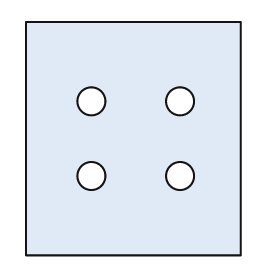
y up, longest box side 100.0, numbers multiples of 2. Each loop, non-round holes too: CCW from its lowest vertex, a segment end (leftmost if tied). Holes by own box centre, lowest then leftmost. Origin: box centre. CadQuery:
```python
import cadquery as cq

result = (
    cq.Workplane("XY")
    .moveTo(-46.0, -50.0)
    .lineTo(46.0, -50.0)
    .lineTo(46.0, 50.0)
    .lineTo(-46.0, 50.0)
    .close()
    .moveTo(-18.0, -16.0)
    .circle(6.0)
    .moveTo(20.0, -16.0)
    .circle(6.0)
    .moveTo(-18.0, 16.0)
    .circle(6.0)
    .moveTo(20.0, 16.0)
    .circle(6.0)
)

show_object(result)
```